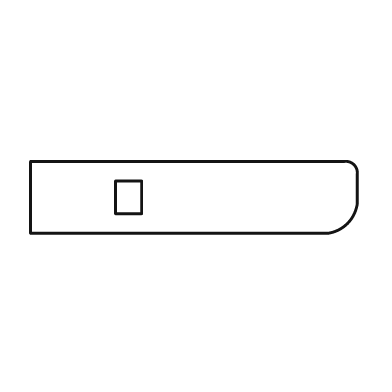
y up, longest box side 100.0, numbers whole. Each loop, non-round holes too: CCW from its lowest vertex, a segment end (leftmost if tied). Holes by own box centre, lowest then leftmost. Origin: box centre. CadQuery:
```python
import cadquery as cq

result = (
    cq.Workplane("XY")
    .moveTo(-50.0, -11.0)
    .lineTo(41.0, -11.0)
    .threePointArc((47.0, -8.0), (50.0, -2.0))
    .lineTo(50.0, 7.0)
    .threePointArc((49.0, 10.0), (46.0, 11.0))
    .lineTo(-50.0, 11.0)
    .close()
    .moveTo(-24.0, -5.0)
    .lineTo(-16.0, -5.0)
    .lineTo(-16.0, 5.0)
    .lineTo(-24.0, 5.0)
    .close()
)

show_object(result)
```